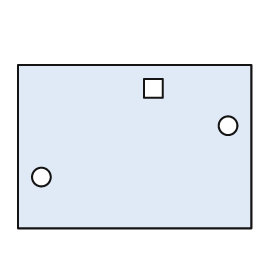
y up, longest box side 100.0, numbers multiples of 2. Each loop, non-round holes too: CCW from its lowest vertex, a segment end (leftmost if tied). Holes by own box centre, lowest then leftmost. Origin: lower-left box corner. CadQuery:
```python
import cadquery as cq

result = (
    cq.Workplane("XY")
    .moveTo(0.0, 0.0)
    .lineTo(100.0, 0.0)
    .lineTo(100.0, 70.0)
    .lineTo(0.0, 70.0)
    .close()
    .moveTo(10.0, 22.0)
    .circle(4.0)
    .moveTo(90.0, 44.0)
    .circle(4.0)
    .moveTo(54.0, 56.0)
    .lineTo(62.0, 56.0)
    .lineTo(62.0, 64.0)
    .lineTo(54.0, 64.0)
    .close()
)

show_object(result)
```